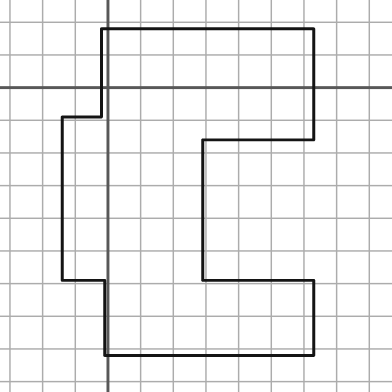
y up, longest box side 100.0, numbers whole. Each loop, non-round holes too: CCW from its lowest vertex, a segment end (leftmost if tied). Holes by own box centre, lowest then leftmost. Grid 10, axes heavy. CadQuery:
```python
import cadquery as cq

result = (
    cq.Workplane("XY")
    .moveTo(-1.0, -82.0)
    .lineTo(63.0, -82.0)
    .lineTo(63.0, -59.0)
    .lineTo(29.0, -59.0)
    .lineTo(29.0, -16.0)
    .lineTo(63.0, -16.0)
    .lineTo(63.0, 18.0)
    .lineTo(-2.0, 18.0)
    .lineTo(-2.0, -9.0)
    .lineTo(-14.0, -9.0)
    .lineTo(-14.0, -59.0)
    .lineTo(-1.0, -59.0)
    .close()
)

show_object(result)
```